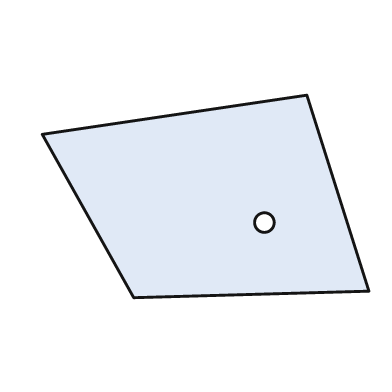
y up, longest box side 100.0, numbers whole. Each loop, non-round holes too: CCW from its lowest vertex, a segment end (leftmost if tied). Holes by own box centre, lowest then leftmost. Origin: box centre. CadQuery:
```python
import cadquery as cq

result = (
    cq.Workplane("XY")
    .moveTo(-22.0, -31.0)
    .lineTo(50.0, -29.0)
    .lineTo(31.0, 31.0)
    .lineTo(-50.0, 19.0)
    .close()
    .moveTo(18.0, -8.0)
    .circle(3.0)
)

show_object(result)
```